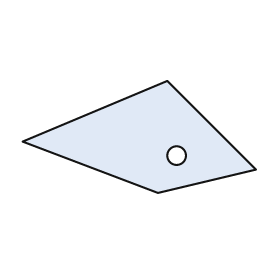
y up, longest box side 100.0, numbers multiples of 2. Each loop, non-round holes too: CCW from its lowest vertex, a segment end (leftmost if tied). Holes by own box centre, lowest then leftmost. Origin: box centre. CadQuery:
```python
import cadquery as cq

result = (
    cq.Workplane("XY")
    .moveTo(8.0, -24.0)
    .lineTo(50.0, -14.0)
    .lineTo(12.0, 24.0)
    .lineTo(-50.0, -2.0)
    .close()
    .moveTo(16.0, -8.0)
    .circle(4.0)
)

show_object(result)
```